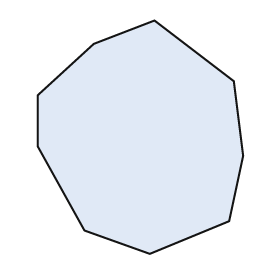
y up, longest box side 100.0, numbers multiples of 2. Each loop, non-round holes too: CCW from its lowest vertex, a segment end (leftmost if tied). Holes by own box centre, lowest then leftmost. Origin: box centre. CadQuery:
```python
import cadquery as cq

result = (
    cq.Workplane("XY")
    .moveTo(4.0, -50.0)
    .lineTo(38.0, -36.0)
    .lineTo(44.0, -8.0)
    .lineTo(40.0, 24.0)
    .lineTo(6.0, 50.0)
    .lineTo(-20.0, 40.0)
    .lineTo(-44.0, 18.0)
    .lineTo(-44.0, -4.0)
    .lineTo(-24.0, -40.0)
    .close()
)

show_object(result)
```